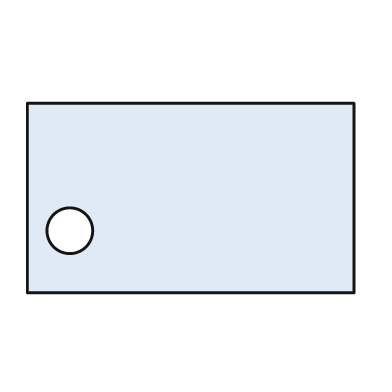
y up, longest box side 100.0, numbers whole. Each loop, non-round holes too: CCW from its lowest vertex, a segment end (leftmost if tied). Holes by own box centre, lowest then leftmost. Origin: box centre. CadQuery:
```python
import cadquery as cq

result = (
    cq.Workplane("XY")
    .moveTo(-50.0, -29.0)
    .lineTo(50.0, -29.0)
    .lineTo(50.0, 29.0)
    .lineTo(-50.0, 29.0)
    .close()
    .moveTo(-37.0, -10.0)
    .circle(7.0)
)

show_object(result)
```